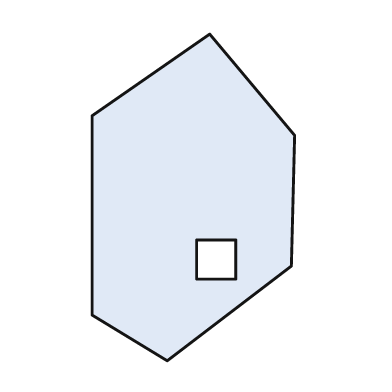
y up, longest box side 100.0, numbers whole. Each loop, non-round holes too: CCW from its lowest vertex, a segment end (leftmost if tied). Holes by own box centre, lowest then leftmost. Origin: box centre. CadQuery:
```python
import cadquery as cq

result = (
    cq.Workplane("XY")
    .moveTo(-8.0, -50.0)
    .lineTo(30.0, -21.0)
    .lineTo(31.0, 19.0)
    .lineTo(5.0, 50.0)
    .lineTo(-31.0, 25.0)
    .lineTo(-31.0, -36.0)
    .close()
    .moveTo(1.0, -25.0)
    .lineTo(13.0, -25.0)
    .lineTo(13.0, -13.0)
    .lineTo(1.0, -13.0)
    .close()
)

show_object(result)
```